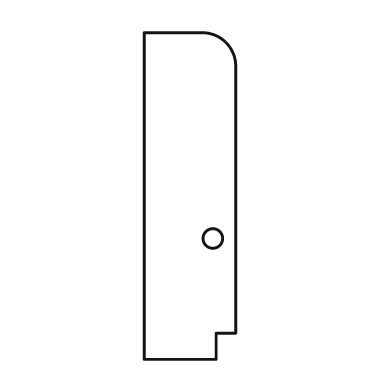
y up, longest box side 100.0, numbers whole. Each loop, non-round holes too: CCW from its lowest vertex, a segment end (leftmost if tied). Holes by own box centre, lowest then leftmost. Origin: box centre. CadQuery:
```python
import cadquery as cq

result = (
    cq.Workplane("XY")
    .moveTo(-14.0, -50.0)
    .lineTo(8.0, -50.0)
    .lineTo(8.0, -42.0)
    .lineTo(14.0, -42.0)
    .lineTo(14.0, 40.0)
    .threePointArc((11.0, 47.0), (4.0, 50.0))
    .lineTo(-14.0, 50.0)
    .close()
    .moveTo(7.0, -13.0)
    .circle(3.0)
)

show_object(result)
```